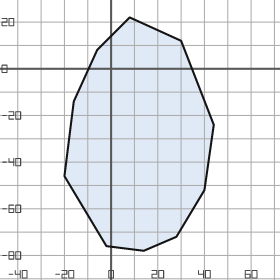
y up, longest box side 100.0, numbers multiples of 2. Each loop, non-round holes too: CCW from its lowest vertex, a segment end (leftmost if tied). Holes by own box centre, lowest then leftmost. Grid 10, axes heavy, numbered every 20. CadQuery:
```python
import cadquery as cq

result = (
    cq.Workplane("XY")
    .moveTo(14.0, -78.0)
    .lineTo(28.0, -72.0)
    .lineTo(40.0, -52.0)
    .lineTo(44.0, -24.0)
    .lineTo(30.0, 12.0)
    .lineTo(8.0, 22.0)
    .lineTo(-6.0, 8.0)
    .lineTo(-16.0, -14.0)
    .lineTo(-20.0, -46.0)
    .lineTo(-2.0, -76.0)
    .close()
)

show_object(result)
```